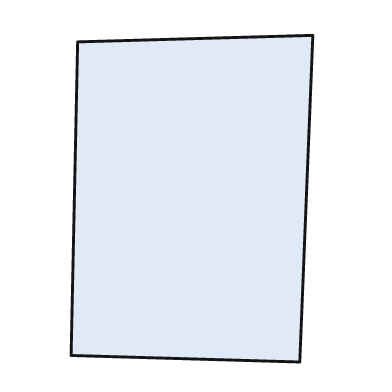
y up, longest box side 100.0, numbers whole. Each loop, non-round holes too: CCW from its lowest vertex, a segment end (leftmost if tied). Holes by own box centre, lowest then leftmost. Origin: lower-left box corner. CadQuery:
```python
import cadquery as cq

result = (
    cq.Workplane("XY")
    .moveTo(70.0, 0.0)
    .lineTo(74.0, 100.0)
    .lineTo(2.0, 98.0)
    .lineTo(0.0, 2.0)
    .close()
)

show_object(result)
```